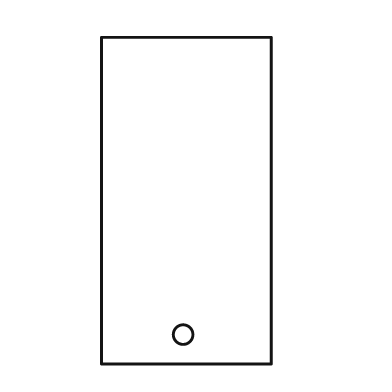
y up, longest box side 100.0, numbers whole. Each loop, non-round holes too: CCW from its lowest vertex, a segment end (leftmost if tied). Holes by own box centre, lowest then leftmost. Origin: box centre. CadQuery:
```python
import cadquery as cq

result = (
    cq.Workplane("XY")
    .moveTo(-26.0, -50.0)
    .lineTo(26.0, -50.0)
    .lineTo(26.0, 50.0)
    .lineTo(-26.0, 50.0)
    .close()
    .moveTo(-1.0, -41.0)
    .circle(3.0)
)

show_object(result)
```